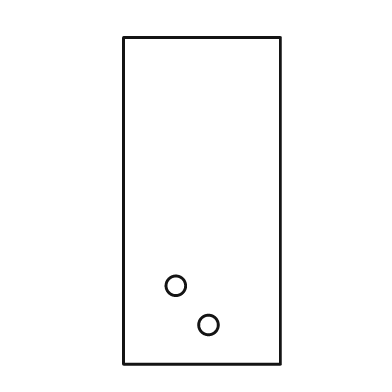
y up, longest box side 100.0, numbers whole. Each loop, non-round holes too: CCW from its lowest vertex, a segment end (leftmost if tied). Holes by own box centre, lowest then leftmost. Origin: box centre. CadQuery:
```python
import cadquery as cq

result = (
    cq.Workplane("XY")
    .moveTo(-24.0, -50.0)
    .lineTo(24.0, -50.0)
    .lineTo(24.0, 50.0)
    .lineTo(-24.0, 50.0)
    .close()
    .moveTo(2.0, -38.0)
    .circle(3.0)
    .moveTo(-8.0, -26.0)
    .circle(3.0)
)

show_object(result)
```